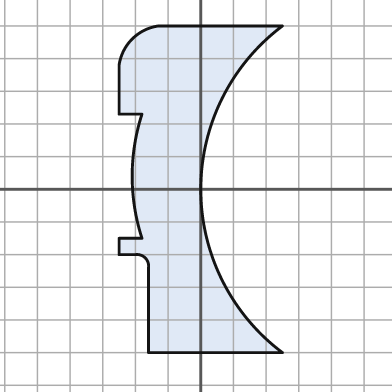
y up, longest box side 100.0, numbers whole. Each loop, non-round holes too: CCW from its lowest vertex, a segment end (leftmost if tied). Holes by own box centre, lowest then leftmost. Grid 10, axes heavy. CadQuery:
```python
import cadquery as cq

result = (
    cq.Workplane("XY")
    .moveTo(-16.0, -50.0)
    .lineTo(25.0, -50.0)
    .threePointArc((0.0, 0.0), (25.0, 50.0))
    .lineTo(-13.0, 50.0)
    .threePointArc((-21.0, 46.0), (-25.0, 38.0))
    .lineTo(-25.0, 23.0)
    .lineTo(-18.0, 23.0)
    .threePointArc((-21.0, 4.0), (-18.0, -15.0))
    .lineTo(-25.0, -15.0)
    .lineTo(-25.0, -20.0)
    .lineTo(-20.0, -20.0)
    .threePointArc((-17.0, -21.0), (-16.0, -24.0))
    .close()
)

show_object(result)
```